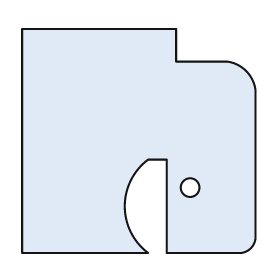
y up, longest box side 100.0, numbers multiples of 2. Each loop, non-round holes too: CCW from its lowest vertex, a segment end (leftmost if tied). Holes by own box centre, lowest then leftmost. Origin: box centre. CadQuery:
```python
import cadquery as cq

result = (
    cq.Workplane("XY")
    .moveTo(-50.0, -48.0)
    .lineTo(4.0, -48.0)
    .threePointArc((-6.0, -28.0), (4.0, -8.0))
    .lineTo(12.0, -8.0)
    .lineTo(12.0, -48.0)
    .lineTo(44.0, -48.0)
    .threePointArc((48.0, -46.0), (50.0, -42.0))
    .lineTo(50.0, 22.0)
    .threePointArc((46.0, 30.0), (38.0, 34.0))
    .lineTo(16.0, 34.0)
    .lineTo(16.0, 48.0)
    .lineTo(-50.0, 48.0)
    .close()
    .moveTo(22.0, -20.0)
    .circle(4.0)
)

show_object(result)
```